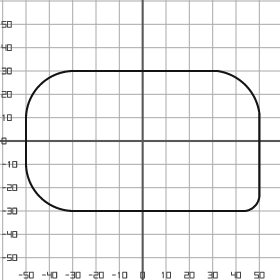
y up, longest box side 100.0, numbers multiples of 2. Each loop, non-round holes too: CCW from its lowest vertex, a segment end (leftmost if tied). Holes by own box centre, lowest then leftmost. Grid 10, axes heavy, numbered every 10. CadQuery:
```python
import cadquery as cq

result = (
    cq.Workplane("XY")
    .moveTo(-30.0, -30.0)
    .lineTo(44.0, -30.0)
    .threePointArc((48.0, -28.0), (50.0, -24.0))
    .lineTo(50.0, 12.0)
    .threePointArc((44.0, 24.0), (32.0, 30.0))
    .lineTo(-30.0, 30.0)
    .threePointArc((-44.0, 24.0), (-50.0, 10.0))
    .lineTo(-50.0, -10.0)
    .threePointArc((-44.0, -24.0), (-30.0, -30.0))
    .close()
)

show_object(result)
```